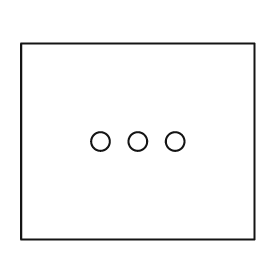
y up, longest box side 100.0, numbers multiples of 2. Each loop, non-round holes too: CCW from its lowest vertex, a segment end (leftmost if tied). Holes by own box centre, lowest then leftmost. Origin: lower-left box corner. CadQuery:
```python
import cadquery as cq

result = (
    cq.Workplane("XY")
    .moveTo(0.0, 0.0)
    .lineTo(100.0, 0.0)
    .lineTo(100.0, 84.0)
    .lineTo(0.0, 84.0)
    .close()
    .moveTo(34.0, 42.0)
    .circle(4.0)
    .moveTo(50.0, 42.0)
    .circle(4.0)
    .moveTo(66.0, 42.0)
    .circle(4.0)
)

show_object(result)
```